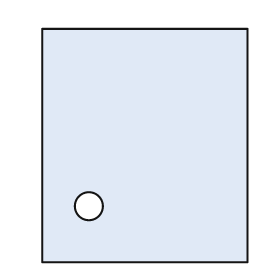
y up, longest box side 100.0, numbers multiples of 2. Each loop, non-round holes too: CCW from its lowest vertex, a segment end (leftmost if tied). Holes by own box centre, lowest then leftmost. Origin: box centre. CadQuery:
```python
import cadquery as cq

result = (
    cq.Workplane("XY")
    .moveTo(-44.0, -50.0)
    .lineTo(44.0, -50.0)
    .lineTo(44.0, 50.0)
    .lineTo(-44.0, 50.0)
    .close()
    .moveTo(-24.0, -26.0)
    .circle(6.0)
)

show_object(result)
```